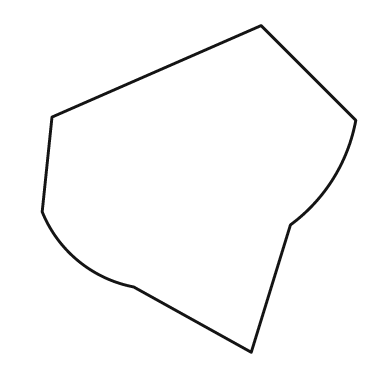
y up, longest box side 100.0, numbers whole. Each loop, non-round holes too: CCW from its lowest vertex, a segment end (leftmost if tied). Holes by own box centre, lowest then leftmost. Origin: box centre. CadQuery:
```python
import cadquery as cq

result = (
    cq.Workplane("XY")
    .moveTo(16.0, -50.0)
    .lineTo(28.0, -11.0)
    .threePointArc((41.0, 3.0), (48.0, 21.0))
    .lineTo(19.0, 50.0)
    .lineTo(-45.0, 22.0)
    .lineTo(-48.0, -7.0)
    .threePointArc((-37.0, -22.0), (-20.0, -30.0))
    .close()
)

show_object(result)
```